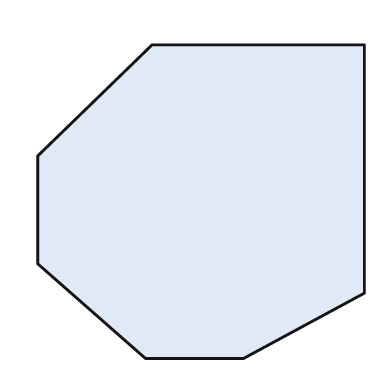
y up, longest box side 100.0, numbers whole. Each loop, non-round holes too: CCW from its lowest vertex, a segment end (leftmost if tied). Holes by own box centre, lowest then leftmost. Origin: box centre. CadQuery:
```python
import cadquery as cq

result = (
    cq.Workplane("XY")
    .moveTo(-17.0, -48.0)
    .lineTo(13.0, -48.0)
    .lineTo(50.0, -28.0)
    .lineTo(50.0, 48.0)
    .lineTo(-15.0, 48.0)
    .lineTo(-50.0, 14.0)
    .lineTo(-50.0, -19.0)
    .close()
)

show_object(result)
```